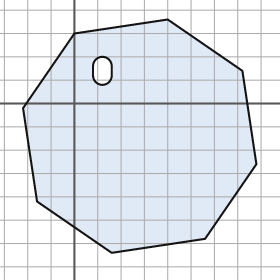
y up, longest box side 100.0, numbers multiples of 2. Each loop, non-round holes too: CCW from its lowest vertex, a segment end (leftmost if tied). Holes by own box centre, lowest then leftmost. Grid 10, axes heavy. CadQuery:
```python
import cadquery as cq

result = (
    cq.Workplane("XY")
    .moveTo(16.0, -64.0)
    .lineTo(56.0, -58.0)
    .lineTo(78.0, -26.0)
    .lineTo(72.0, 14.0)
    .lineTo(40.0, 36.0)
    .lineTo(0.0, 30.0)
    .lineTo(-22.0, -2.0)
    .lineTo(-16.0, -42.0)
    .close()
    .moveTo(8.0, 12.0)
    .threePointArc((12.0, 8.0), (16.0, 12.0))
    .lineTo(16.0, 16.0)
    .threePointArc((12.0, 20.0), (8.0, 16.0))
    .close()
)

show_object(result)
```